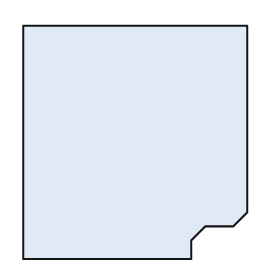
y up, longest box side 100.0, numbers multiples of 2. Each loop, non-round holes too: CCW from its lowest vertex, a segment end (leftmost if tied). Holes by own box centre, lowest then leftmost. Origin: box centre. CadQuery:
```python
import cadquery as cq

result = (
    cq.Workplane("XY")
    .moveTo(-48.0, -50.0)
    .lineTo(24.0, -50.0)
    .lineTo(24.0, -42.0)
    .lineTo(30.0, -36.0)
    .lineTo(42.0, -36.0)
    .lineTo(48.0, -30.0)
    .lineTo(48.0, 50.0)
    .lineTo(-48.0, 50.0)
    .close()
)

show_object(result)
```